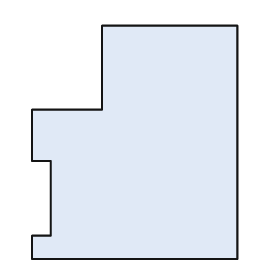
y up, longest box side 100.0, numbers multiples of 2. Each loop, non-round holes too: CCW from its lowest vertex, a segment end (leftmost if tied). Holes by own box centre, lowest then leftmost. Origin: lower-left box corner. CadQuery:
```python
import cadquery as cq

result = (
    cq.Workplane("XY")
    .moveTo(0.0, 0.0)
    .lineTo(88.0, 0.0)
    .lineTo(88.0, 100.0)
    .lineTo(30.0, 100.0)
    .lineTo(30.0, 64.0)
    .lineTo(0.0, 64.0)
    .lineTo(0.0, 42.0)
    .lineTo(8.0, 42.0)
    .lineTo(8.0, 10.0)
    .lineTo(0.0, 10.0)
    .close()
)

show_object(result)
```